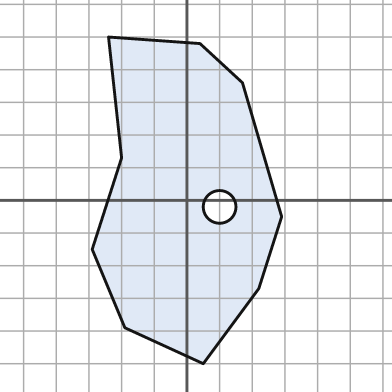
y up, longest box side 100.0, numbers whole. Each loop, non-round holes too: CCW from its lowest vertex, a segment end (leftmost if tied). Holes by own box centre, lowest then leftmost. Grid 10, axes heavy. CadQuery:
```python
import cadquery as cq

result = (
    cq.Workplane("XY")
    .moveTo(5.0, -50.0)
    .lineTo(22.0, -27.0)
    .lineTo(29.0, -5.0)
    .lineTo(17.0, 36.0)
    .lineTo(4.0, 48.0)
    .lineTo(-24.0, 50.0)
    .lineTo(-20.0, 13.0)
    .lineTo(-29.0, -15.0)
    .lineTo(-19.0, -39.0)
    .close()
    .moveTo(10.0, -2.0)
    .circle(5.0)
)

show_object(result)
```